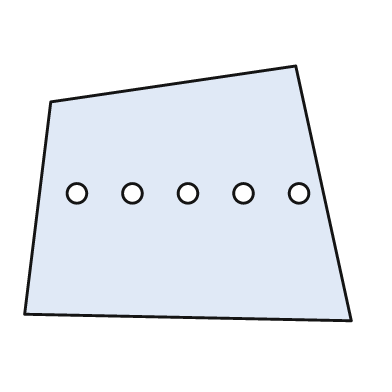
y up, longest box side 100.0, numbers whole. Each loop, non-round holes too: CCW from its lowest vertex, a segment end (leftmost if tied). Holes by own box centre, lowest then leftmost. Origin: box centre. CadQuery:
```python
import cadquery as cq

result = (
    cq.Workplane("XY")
    .moveTo(50.0, -39.0)
    .lineTo(33.0, 39.0)
    .lineTo(-42.0, 28.0)
    .lineTo(-50.0, -37.0)
    .close()
    .moveTo(-34.0, 0.0)
    .circle(3.0)
    .moveTo(-17.0, 0.0)
    .circle(3.0)
    .moveTo(0.0, 0.0)
    .circle(3.0)
    .moveTo(17.0, 0.0)
    .circle(3.0)
    .moveTo(34.0, 0.0)
    .circle(3.0)
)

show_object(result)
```